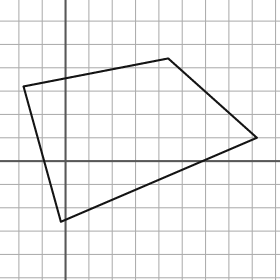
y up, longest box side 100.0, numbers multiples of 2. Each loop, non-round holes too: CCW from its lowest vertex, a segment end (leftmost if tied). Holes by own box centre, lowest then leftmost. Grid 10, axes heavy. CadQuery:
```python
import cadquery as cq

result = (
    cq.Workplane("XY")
    .moveTo(-2.0, -26.0)
    .lineTo(82.0, 10.0)
    .lineTo(44.0, 44.0)
    .lineTo(-18.0, 32.0)
    .close()
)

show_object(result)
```